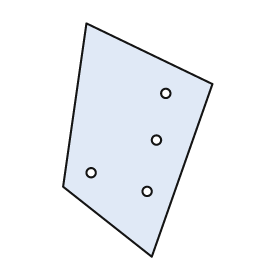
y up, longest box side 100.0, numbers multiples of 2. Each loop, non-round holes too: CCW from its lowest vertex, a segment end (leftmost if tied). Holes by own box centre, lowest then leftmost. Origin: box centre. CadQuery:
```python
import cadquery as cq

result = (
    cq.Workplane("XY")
    .moveTo(6.0, -50.0)
    .lineTo(32.0, 24.0)
    .lineTo(-22.0, 50.0)
    .lineTo(-32.0, -20.0)
    .close()
    .moveTo(4.0, -22.0)
    .circle(2.0)
    .moveTo(-20.0, -14.0)
    .circle(2.0)
    .moveTo(8.0, 0.0)
    .circle(2.0)
    .moveTo(12.0, 20.0)
    .circle(2.0)
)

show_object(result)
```